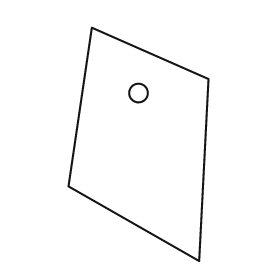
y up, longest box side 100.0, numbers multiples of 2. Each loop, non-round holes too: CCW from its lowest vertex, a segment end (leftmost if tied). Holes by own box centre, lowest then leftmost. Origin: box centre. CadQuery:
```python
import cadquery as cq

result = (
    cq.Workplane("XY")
    .moveTo(26.0, -50.0)
    .lineTo(30.0, 28.0)
    .lineTo(-20.0, 50.0)
    .lineTo(-30.0, -18.0)
    .close()
    .moveTo(0.0, 22.0)
    .circle(4.0)
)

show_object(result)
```